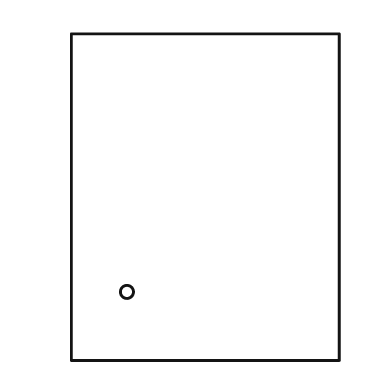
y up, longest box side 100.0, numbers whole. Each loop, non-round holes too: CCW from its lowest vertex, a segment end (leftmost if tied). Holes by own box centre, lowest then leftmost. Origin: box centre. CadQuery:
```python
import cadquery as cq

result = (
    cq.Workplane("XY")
    .moveTo(-41.0, -50.0)
    .lineTo(41.0, -50.0)
    .lineTo(41.0, 50.0)
    .lineTo(-41.0, 50.0)
    .close()
    .moveTo(-24.0, -29.0)
    .circle(2.0)
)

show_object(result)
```